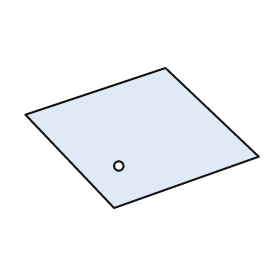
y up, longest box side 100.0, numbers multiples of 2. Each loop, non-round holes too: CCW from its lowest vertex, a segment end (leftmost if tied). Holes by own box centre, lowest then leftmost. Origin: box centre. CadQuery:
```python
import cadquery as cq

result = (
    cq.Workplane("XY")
    .moveTo(-12.0, -30.0)
    .lineTo(50.0, -8.0)
    .lineTo(10.0, 30.0)
    .lineTo(-50.0, 10.0)
    .close()
    .moveTo(-10.0, -12.0)
    .circle(2.0)
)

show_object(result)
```